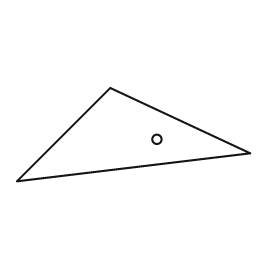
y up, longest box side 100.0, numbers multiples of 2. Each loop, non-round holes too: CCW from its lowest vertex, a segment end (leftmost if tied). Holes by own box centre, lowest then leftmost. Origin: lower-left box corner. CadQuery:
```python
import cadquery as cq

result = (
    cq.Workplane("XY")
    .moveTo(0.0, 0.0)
    .lineTo(100.0, 12.0)
    .lineTo(40.0, 40.0)
    .close()
    .moveTo(60.0, 18.0)
    .circle(2.0)
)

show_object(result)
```